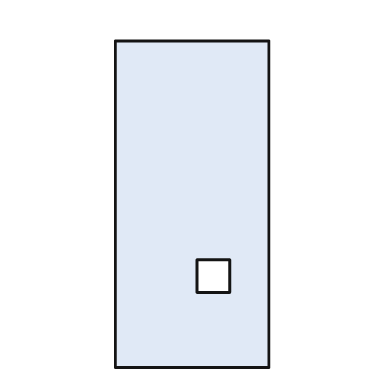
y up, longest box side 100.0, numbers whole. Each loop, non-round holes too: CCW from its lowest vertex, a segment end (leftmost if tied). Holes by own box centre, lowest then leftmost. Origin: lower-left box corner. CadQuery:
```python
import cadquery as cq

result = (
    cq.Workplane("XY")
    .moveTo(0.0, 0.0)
    .lineTo(47.0, 0.0)
    .lineTo(47.0, 100.0)
    .lineTo(0.0, 100.0)
    .close()
    .moveTo(25.0, 23.0)
    .lineTo(35.0, 23.0)
    .lineTo(35.0, 33.0)
    .lineTo(25.0, 33.0)
    .close()
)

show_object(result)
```